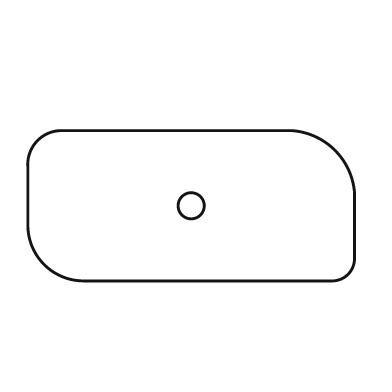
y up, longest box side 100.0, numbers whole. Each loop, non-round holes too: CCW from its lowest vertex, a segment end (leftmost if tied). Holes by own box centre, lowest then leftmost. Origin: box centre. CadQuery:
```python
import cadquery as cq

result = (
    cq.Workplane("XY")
    .moveTo(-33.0, -23.0)
    .lineTo(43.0, -23.0)
    .threePointArc((48.0, -21.0), (50.0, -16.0))
    .lineTo(50.0, 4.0)
    .threePointArc((44.0, 17.0), (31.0, 23.0))
    .lineTo(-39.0, 23.0)
    .threePointArc((-47.0, 20.0), (-50.0, 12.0))
    .lineTo(-50.0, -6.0)
    .threePointArc((-45.0, -18.0), (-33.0, -23.0))
    .close()
    .moveTo(0.0, 0.0)
    .circle(4.0)
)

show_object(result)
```